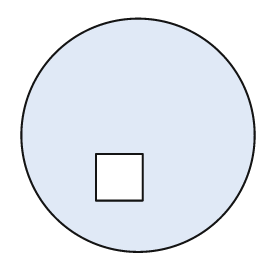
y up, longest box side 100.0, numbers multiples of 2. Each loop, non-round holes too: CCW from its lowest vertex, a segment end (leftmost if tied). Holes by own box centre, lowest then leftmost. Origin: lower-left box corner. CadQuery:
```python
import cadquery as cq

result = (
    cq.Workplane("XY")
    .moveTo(50.0, 50.0)
    .circle(50.0)
    .moveTo(32.0, 22.0)
    .lineTo(52.0, 22.0)
    .lineTo(52.0, 42.0)
    .lineTo(32.0, 42.0)
    .close()
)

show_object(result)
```